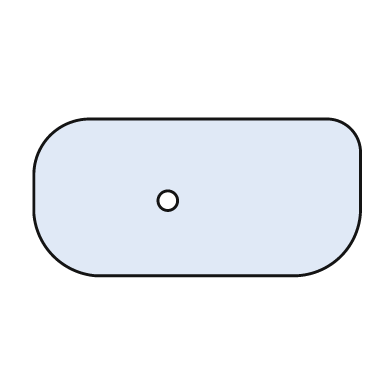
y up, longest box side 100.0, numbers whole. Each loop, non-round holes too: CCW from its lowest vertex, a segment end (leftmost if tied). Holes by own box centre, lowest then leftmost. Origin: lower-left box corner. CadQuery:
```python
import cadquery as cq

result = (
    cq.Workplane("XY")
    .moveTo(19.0, 0.0)
    .lineTo(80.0, 0.0)
    .threePointArc((94.0, 6.0), (100.0, 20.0))
    .lineTo(100.0, 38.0)
    .threePointArc((97.0, 45.0), (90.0, 48.0))
    .lineTo(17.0, 48.0)
    .threePointArc((5.0, 43.0), (0.0, 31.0))
    .lineTo(0.0, 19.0)
    .threePointArc((6.0, 6.0), (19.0, 0.0))
    .close()
    .moveTo(41.0, 23.0)
    .circle(3.0)
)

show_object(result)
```